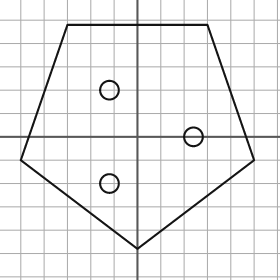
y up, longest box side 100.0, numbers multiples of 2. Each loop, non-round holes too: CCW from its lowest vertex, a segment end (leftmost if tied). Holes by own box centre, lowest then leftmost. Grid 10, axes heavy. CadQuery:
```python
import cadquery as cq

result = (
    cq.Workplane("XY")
    .moveTo(0.0, -48.0)
    .lineTo(50.0, -10.0)
    .lineTo(30.0, 48.0)
    .lineTo(-30.0, 48.0)
    .lineTo(-50.0, -10.0)
    .close()
    .moveTo(-12.0, -20.0)
    .circle(4.0)
    .moveTo(24.0, 0.0)
    .circle(4.0)
    .moveTo(-12.0, 20.0)
    .circle(4.0)
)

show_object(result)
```